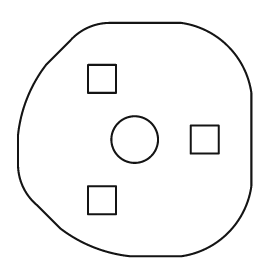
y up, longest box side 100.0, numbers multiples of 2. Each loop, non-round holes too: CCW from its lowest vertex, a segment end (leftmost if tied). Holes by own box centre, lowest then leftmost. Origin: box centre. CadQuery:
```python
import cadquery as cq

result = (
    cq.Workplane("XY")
    .moveTo(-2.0, -50.0)
    .lineTo(20.0, -50.0)
    .threePointArc((40.0, -40.0), (50.0, -20.0))
    .lineTo(50.0, 20.0)
    .threePointArc((40.0, 40.0), (20.0, 50.0))
    .lineTo(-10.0, 50.0)
    .threePointArc((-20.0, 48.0), (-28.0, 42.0))
    .lineTo(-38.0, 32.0)
    .threePointArc((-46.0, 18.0), (-50.0, 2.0))
    .lineTo(-50.0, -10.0)
    .threePointArc((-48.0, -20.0), (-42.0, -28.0))
    .lineTo(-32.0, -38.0)
    .threePointArc((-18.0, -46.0), (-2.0, -50.0))
    .close()
    .moveTo(-20.0, -32.0)
    .lineTo(-8.0, -32.0)
    .lineTo(-8.0, -20.0)
    .lineTo(-20.0, -20.0)
    .close()
    .moveTo(0.0, 0.0)
    .circle(10.0)
    .moveTo(24.0, -6.0)
    .lineTo(36.0, -6.0)
    .lineTo(36.0, 6.0)
    .lineTo(24.0, 6.0)
    .close()
    .moveTo(-20.0, 20.0)
    .lineTo(-8.0, 20.0)
    .lineTo(-8.0, 32.0)
    .lineTo(-20.0, 32.0)
    .close()
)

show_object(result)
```